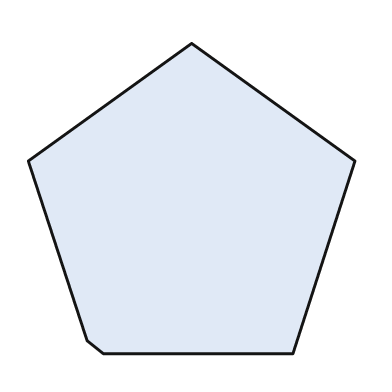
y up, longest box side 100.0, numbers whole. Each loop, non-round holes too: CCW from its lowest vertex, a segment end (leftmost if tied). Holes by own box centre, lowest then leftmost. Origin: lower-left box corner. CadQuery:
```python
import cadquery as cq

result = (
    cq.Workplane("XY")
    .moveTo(23.0, 0.0)
    .lineTo(81.0, 0.0)
    .lineTo(100.0, 59.0)
    .lineTo(50.0, 95.0)
    .lineTo(0.0, 59.0)
    .lineTo(18.0, 4.0)
    .close()
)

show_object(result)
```